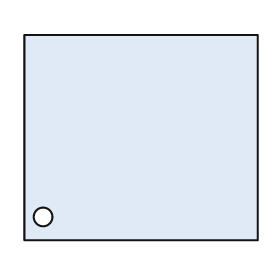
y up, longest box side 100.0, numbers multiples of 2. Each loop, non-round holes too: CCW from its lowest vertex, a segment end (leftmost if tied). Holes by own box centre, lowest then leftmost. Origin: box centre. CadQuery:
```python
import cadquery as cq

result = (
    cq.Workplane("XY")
    .moveTo(-50.0, -44.0)
    .lineTo(50.0, -44.0)
    .lineTo(50.0, 44.0)
    .lineTo(-50.0, 44.0)
    .close()
    .moveTo(-42.0, -34.0)
    .circle(4.0)
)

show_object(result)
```